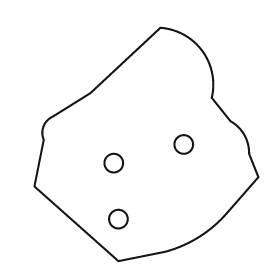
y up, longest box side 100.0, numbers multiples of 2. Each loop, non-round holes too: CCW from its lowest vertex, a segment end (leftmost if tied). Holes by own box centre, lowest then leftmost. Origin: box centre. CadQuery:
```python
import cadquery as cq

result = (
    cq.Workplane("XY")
    .moveTo(-12.0, -50.0)
    .lineTo(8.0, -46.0)
    .threePointArc((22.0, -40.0), (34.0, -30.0))
    .lineTo(48.0, -14.0)
    .lineTo(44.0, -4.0)
    .threePointArc((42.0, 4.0), (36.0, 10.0))
    .lineTo(28.0, 20.0)
    .threePointArc((24.0, 40.0), (6.0, 50.0))
    .lineTo(-24.0, 22.0)
    .lineTo(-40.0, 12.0)
    .threePointArc((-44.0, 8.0), (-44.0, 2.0))
    .lineTo(-48.0, -18.0)
    .close()
    .moveTo(-12.0, -32.0)
    .circle(4.0)
    .moveTo(-14.0, -8.0)
    .circle(4.0)
    .moveTo(16.0, 0.0)
    .circle(4.0)
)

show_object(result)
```